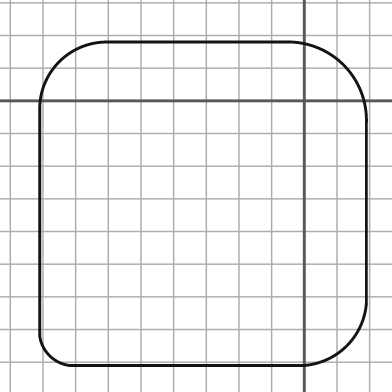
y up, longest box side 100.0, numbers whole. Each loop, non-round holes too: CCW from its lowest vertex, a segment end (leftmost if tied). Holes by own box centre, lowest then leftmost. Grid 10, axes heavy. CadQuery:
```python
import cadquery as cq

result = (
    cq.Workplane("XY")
    .moveTo(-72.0, -81.0)
    .lineTo(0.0, -81.0)
    .threePointArc((13.0, -75.0), (19.0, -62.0))
    .lineTo(19.0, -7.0)
    .threePointArc((12.0, 11.0), (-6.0, 18.0))
    .lineTo(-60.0, 18.0)
    .threePointArc((-75.0, 12.0), (-81.0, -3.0))
    .lineTo(-81.0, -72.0)
    .threePointArc((-78.0, -78.0), (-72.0, -81.0))
    .close()
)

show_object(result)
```